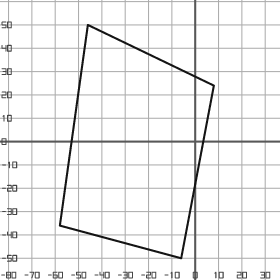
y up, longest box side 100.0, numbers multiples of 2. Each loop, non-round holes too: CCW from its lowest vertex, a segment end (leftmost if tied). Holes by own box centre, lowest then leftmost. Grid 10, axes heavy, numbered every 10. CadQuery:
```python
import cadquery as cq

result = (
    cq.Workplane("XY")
    .moveTo(-6.0, -50.0)
    .lineTo(8.0, 24.0)
    .lineTo(-46.0, 50.0)
    .lineTo(-58.0, -36.0)
    .close()
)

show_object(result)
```